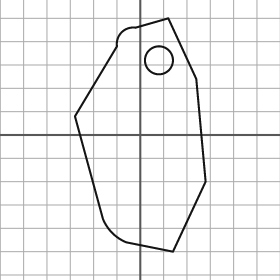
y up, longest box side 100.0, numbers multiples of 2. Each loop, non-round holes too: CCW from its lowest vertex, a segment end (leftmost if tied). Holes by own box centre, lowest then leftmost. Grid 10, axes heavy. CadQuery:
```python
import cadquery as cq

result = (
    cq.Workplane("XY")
    .moveTo(14.0, -50.0)
    .lineTo(28.0, -20.0)
    .lineTo(24.0, 24.0)
    .lineTo(12.0, 50.0)
    .lineTo(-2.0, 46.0)
    .threePointArc((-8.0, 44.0), (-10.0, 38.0))
    .lineTo(-28.0, 8.0)
    .lineTo(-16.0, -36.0)
    .threePointArc((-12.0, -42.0), (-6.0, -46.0))
    .close()
    .moveTo(8.0, 32.0)
    .circle(6.0)
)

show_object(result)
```